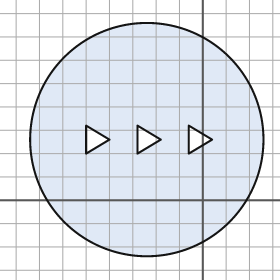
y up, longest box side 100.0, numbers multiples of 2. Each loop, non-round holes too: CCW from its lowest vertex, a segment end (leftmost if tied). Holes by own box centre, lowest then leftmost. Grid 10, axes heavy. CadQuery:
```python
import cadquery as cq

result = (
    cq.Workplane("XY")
    .moveTo(-24.0, 26.0)
    .circle(50.0)
    .moveTo(-50.0, 20.0)
    .lineTo(-40.0, 26.0)
    .lineTo(-50.0, 32.0)
    .close()
    .moveTo(-28.0, 20.0)
    .lineTo(-18.0, 26.0)
    .lineTo(-28.0, 32.0)
    .close()
    .moveTo(-6.0, 20.0)
    .lineTo(4.0, 26.0)
    .lineTo(-6.0, 32.0)
    .close()
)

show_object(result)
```